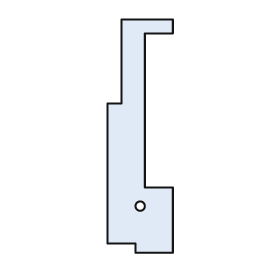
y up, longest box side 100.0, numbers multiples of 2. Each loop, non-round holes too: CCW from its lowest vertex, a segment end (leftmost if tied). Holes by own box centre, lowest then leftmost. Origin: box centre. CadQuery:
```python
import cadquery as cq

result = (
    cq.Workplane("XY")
    .moveTo(-2.0, -50.0)
    .lineTo(14.0, -50.0)
    .lineTo(14.0, -22.0)
    .lineTo(2.0, -22.0)
    .lineTo(2.0, 44.0)
    .lineTo(14.0, 44.0)
    .lineTo(14.0, 50.0)
    .lineTo(-8.0, 50.0)
    .lineTo(-8.0, 14.0)
    .lineTo(-14.0, 14.0)
    .lineTo(-14.0, -46.0)
    .lineTo(-2.0, -46.0)
    .close()
    .moveTo(0.0, -30.0)
    .circle(2.0)
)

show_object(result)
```